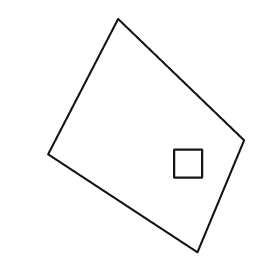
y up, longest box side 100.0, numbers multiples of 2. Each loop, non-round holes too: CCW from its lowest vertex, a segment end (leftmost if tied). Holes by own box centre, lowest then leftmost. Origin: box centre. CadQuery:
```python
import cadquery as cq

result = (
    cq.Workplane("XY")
    .moveTo(22.0, -50.0)
    .lineTo(42.0, -2.0)
    .lineTo(-12.0, 50.0)
    .lineTo(-42.0, -8.0)
    .close()
    .moveTo(12.0, -18.0)
    .lineTo(24.0, -18.0)
    .lineTo(24.0, -6.0)
    .lineTo(12.0, -6.0)
    .close()
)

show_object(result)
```